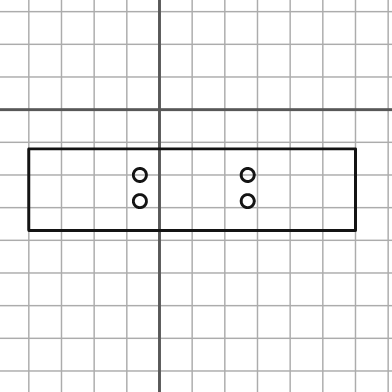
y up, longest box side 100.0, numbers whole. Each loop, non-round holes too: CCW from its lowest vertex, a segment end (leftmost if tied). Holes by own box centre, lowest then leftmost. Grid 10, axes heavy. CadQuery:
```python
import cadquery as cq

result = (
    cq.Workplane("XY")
    .moveTo(-40.0, -37.0)
    .lineTo(60.0, -37.0)
    .lineTo(60.0, -12.0)
    .lineTo(-40.0, -12.0)
    .close()
    .moveTo(-6.0, -28.0)
    .circle(2.0)
    .moveTo(27.0, -28.0)
    .circle(2.0)
    .moveTo(-6.0, -20.0)
    .circle(2.0)
    .moveTo(27.0, -20.0)
    .circle(2.0)
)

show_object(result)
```